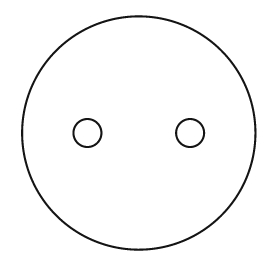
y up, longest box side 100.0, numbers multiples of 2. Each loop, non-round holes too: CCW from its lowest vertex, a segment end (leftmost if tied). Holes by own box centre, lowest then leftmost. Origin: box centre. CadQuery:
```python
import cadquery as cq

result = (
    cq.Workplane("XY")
    .moveTo(0.0, 0.0)
    .circle(50.0)
    .moveTo(-22.0, 0.0)
    .circle(6.0)
    .moveTo(22.0, 0.0)
    .circle(6.0)
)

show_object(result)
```